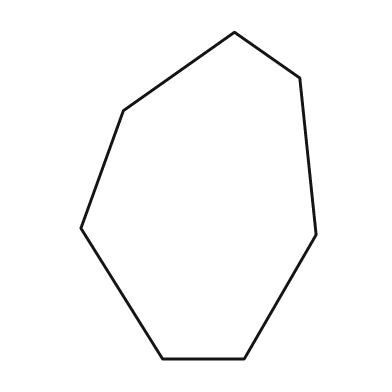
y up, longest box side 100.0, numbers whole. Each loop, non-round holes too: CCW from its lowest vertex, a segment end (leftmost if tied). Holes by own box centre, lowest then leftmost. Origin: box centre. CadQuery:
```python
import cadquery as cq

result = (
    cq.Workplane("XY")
    .moveTo(-11.0, -50.0)
    .lineTo(14.0, -50.0)
    .lineTo(36.0, -12.0)
    .lineTo(31.0, 36.0)
    .lineTo(11.0, 50.0)
    .lineTo(-23.0, 26.0)
    .lineTo(-36.0, -10.0)
    .close()
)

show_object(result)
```